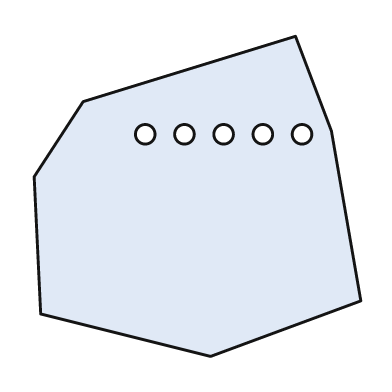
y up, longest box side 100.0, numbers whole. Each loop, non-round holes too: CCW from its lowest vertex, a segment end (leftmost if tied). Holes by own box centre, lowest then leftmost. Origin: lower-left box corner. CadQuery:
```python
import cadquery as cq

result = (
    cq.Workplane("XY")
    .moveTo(54.0, 0.0)
    .lineTo(100.0, 17.0)
    .lineTo(91.0, 69.0)
    .lineTo(80.0, 98.0)
    .lineTo(15.0, 78.0)
    .lineTo(0.0, 55.0)
    .lineTo(2.0, 13.0)
    .close()
    .moveTo(34.0, 68.0)
    .circle(3.0)
    .moveTo(46.0, 68.0)
    .circle(3.0)
    .moveTo(58.0, 68.0)
    .circle(3.0)
    .moveTo(70.0, 68.0)
    .circle(3.0)
    .moveTo(82.0, 68.0)
    .circle(3.0)
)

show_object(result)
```